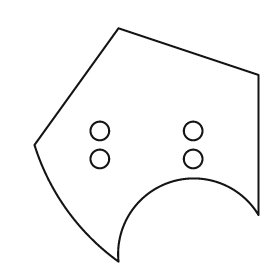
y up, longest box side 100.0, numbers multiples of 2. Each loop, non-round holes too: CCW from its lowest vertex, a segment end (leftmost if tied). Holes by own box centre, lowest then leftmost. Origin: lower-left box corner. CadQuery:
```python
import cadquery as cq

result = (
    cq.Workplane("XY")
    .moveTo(36.0, 0.0)
    .threePointArc((58.0, 34.0), (96.0, 20.0))
    .lineTo(96.0, 80.0)
    .lineTo(36.0, 100.0)
    .lineTo(0.0, 50.0)
    .threePointArc((14.0, 22.0), (36.0, 0.0))
    .close()
    .moveTo(28.0, 44.0)
    .circle(4.0)
    .moveTo(68.0, 44.0)
    .circle(4.0)
    .moveTo(28.0, 56.0)
    .circle(4.0)
    .moveTo(68.0, 56.0)
    .circle(4.0)
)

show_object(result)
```